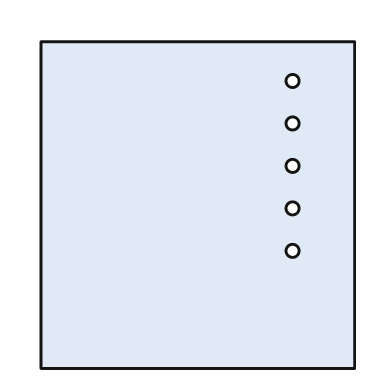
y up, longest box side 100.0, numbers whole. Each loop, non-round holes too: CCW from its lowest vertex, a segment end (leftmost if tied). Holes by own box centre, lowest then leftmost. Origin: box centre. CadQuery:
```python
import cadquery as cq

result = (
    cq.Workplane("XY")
    .moveTo(-48.0, -50.0)
    .lineTo(48.0, -50.0)
    .lineTo(48.0, 50.0)
    .lineTo(-48.0, 50.0)
    .close()
    .moveTo(29.0, -14.0)
    .circle(2.0)
    .moveTo(29.0, -1.0)
    .circle(2.0)
    .moveTo(29.0, 12.0)
    .circle(2.0)
    .moveTo(29.0, 25.0)
    .circle(2.0)
    .moveTo(29.0, 38.0)
    .circle(2.0)
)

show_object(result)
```